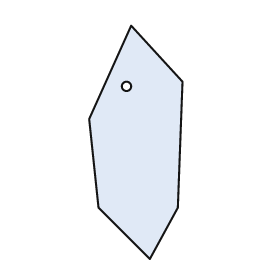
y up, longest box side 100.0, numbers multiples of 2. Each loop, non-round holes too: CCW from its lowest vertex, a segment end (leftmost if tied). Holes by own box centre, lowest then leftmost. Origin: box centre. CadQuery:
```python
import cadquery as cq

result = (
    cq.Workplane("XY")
    .moveTo(6.0, -50.0)
    .lineTo(18.0, -28.0)
    .lineTo(20.0, 26.0)
    .lineTo(-2.0, 50.0)
    .lineTo(-20.0, 10.0)
    .lineTo(-16.0, -28.0)
    .close()
    .moveTo(-4.0, 24.0)
    .circle(2.0)
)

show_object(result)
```